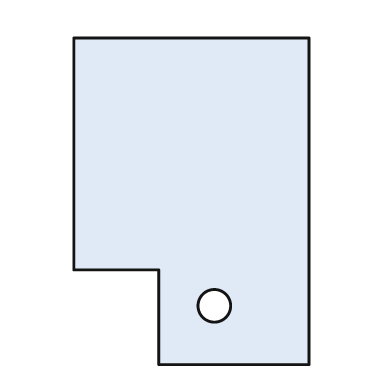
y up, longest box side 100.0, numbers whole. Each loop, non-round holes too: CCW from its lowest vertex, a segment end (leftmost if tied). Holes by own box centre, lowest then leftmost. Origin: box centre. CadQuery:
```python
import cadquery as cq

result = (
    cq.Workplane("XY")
    .moveTo(-10.0, -50.0)
    .lineTo(36.0, -50.0)
    .lineTo(36.0, 50.0)
    .lineTo(-36.0, 50.0)
    .lineTo(-36.0, -21.0)
    .lineTo(-10.0, -21.0)
    .close()
    .moveTo(7.0, -32.0)
    .circle(5.0)
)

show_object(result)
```